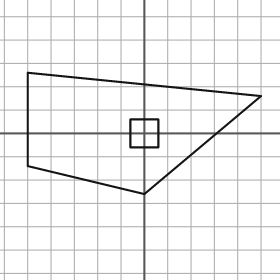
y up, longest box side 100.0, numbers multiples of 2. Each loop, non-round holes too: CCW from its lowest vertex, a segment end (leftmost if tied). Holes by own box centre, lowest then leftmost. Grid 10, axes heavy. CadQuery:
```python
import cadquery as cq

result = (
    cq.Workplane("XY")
    .moveTo(0.0, -26.0)
    .lineTo(50.0, 16.0)
    .lineTo(-50.0, 26.0)
    .lineTo(-50.0, -14.0)
    .close()
    .moveTo(-6.0, -6.0)
    .lineTo(6.0, -6.0)
    .lineTo(6.0, 6.0)
    .lineTo(-6.0, 6.0)
    .close()
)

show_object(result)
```